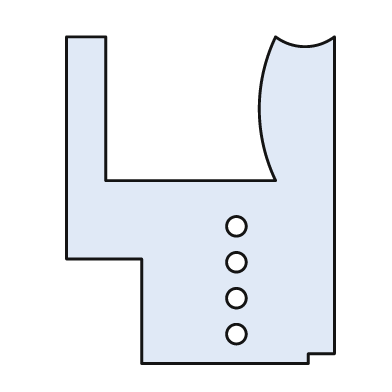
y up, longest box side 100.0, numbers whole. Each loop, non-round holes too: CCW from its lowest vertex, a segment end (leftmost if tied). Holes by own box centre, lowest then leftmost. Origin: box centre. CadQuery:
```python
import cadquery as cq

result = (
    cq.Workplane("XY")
    .moveTo(-18.0, -50.0)
    .lineTo(33.0, -50.0)
    .lineTo(33.0, -47.0)
    .lineTo(41.0, -47.0)
    .lineTo(41.0, 50.0)
    .threePointArc((32.0, 47.0), (23.0, 50.0))
    .threePointArc((18.0, 28.0), (23.0, 6.0))
    .lineTo(-29.0, 6.0)
    .lineTo(-29.0, 50.0)
    .lineTo(-41.0, 50.0)
    .lineTo(-41.0, -18.0)
    .lineTo(-18.0, -18.0)
    .close()
    .moveTo(11.0, -41.0)
    .circle(3.0)
    .moveTo(11.0, -30.0)
    .circle(3.0)
    .moveTo(11.0, -19.0)
    .circle(3.0)
    .moveTo(11.0, -8.0)
    .circle(3.0)
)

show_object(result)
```